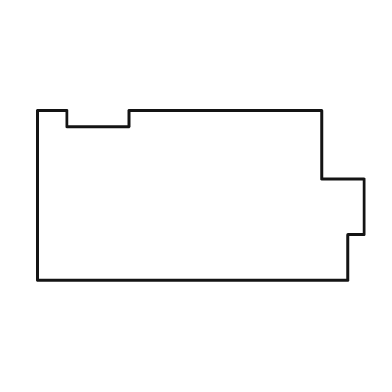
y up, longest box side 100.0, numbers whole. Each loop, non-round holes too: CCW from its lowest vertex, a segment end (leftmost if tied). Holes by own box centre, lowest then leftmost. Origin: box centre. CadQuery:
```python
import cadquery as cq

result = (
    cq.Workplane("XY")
    .moveTo(-50.0, -26.0)
    .lineTo(45.0, -26.0)
    .lineTo(45.0, -12.0)
    .lineTo(50.0, -12.0)
    .lineTo(50.0, 5.0)
    .lineTo(37.0, 5.0)
    .lineTo(37.0, 26.0)
    .lineTo(-22.0, 26.0)
    .lineTo(-22.0, 21.0)
    .lineTo(-41.0, 21.0)
    .lineTo(-41.0, 26.0)
    .lineTo(-50.0, 26.0)
    .close()
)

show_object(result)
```